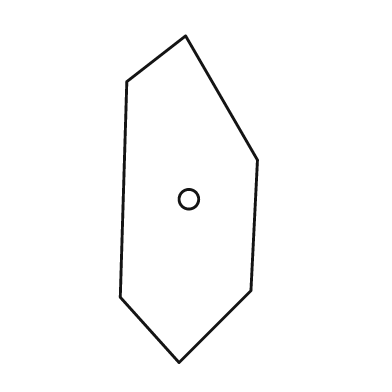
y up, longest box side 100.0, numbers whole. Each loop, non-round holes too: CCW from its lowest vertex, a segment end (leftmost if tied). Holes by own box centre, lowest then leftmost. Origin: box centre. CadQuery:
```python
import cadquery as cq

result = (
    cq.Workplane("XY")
    .moveTo(-3.0, -50.0)
    .lineTo(19.0, -28.0)
    .lineTo(21.0, 12.0)
    .lineTo(-1.0, 50.0)
    .lineTo(-19.0, 36.0)
    .lineTo(-21.0, -30.0)
    .close()
    .moveTo(0.0, 0.0)
    .circle(3.0)
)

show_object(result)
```